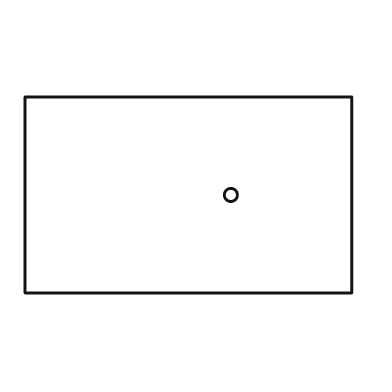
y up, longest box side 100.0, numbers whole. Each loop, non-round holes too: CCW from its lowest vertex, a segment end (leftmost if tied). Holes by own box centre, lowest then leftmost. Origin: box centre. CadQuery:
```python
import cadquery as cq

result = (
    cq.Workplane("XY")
    .moveTo(-50.0, -30.0)
    .lineTo(50.0, -30.0)
    .lineTo(50.0, 30.0)
    .lineTo(-50.0, 30.0)
    .close()
    .moveTo(13.0, 0.0)
    .circle(2.0)
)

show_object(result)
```